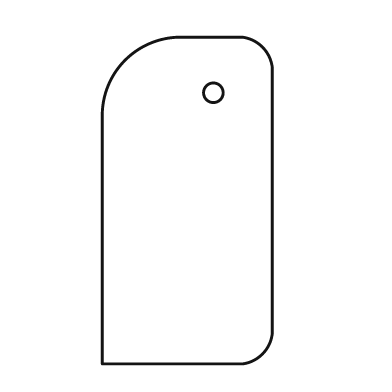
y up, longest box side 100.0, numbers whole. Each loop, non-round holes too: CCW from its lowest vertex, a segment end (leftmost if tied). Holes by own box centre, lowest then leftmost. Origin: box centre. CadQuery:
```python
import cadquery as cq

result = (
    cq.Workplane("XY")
    .moveTo(-26.0, -50.0)
    .lineTo(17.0, -50.0)
    .threePointArc((23.0, -47.0), (26.0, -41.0))
    .lineTo(26.0, 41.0)
    .threePointArc((23.0, 47.0), (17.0, 50.0))
    .lineTo(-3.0, 50.0)
    .threePointArc((-19.0, 43.0), (-26.0, 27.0))
    .close()
    .moveTo(8.0, 33.0)
    .circle(3.0)
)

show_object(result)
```